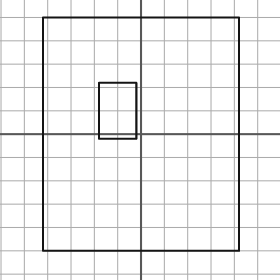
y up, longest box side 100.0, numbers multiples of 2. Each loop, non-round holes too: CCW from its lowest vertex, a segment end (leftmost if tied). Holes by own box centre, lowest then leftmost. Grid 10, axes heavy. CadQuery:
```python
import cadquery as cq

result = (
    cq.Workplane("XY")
    .moveTo(-42.0, -50.0)
    .lineTo(42.0, -50.0)
    .lineTo(42.0, 50.0)
    .lineTo(-42.0, 50.0)
    .close()
    .moveTo(-18.0, -2.0)
    .lineTo(-2.0, -2.0)
    .lineTo(-2.0, 22.0)
    .lineTo(-18.0, 22.0)
    .close()
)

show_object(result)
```